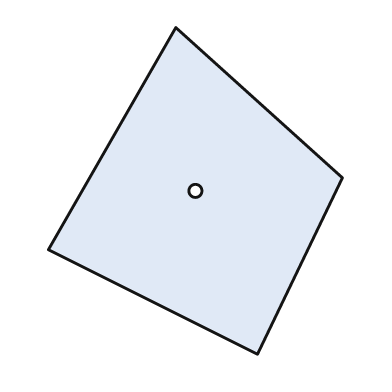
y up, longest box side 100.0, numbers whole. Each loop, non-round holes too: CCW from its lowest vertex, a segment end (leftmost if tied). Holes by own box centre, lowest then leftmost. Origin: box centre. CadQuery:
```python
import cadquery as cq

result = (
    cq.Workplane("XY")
    .moveTo(19.0, -50.0)
    .lineTo(45.0, 4.0)
    .lineTo(-6.0, 50.0)
    .lineTo(-45.0, -18.0)
    .close()
    .moveTo(0.0, 0.0)
    .circle(2.0)
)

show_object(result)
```